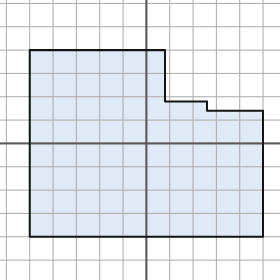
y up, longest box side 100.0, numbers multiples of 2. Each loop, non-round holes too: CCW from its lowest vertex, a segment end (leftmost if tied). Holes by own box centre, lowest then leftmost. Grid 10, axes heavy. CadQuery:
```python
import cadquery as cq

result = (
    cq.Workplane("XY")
    .moveTo(-50.0, -40.0)
    .lineTo(50.0, -40.0)
    .lineTo(50.0, 14.0)
    .lineTo(26.0, 14.0)
    .lineTo(26.0, 18.0)
    .lineTo(8.0, 18.0)
    .lineTo(8.0, 40.0)
    .lineTo(-50.0, 40.0)
    .close()
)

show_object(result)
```